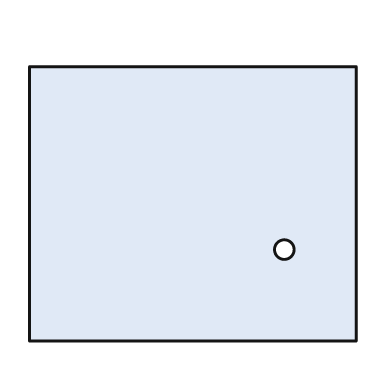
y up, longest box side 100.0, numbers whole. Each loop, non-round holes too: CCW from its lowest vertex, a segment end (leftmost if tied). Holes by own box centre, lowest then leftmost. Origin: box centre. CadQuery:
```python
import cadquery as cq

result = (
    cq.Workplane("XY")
    .moveTo(-50.0, -42.0)
    .lineTo(50.0, -42.0)
    .lineTo(50.0, 42.0)
    .lineTo(-50.0, 42.0)
    .close()
    .moveTo(28.0, -14.0)
    .circle(3.0)
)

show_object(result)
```